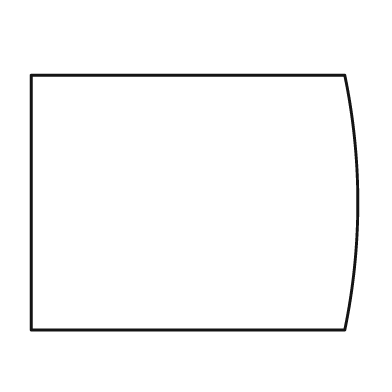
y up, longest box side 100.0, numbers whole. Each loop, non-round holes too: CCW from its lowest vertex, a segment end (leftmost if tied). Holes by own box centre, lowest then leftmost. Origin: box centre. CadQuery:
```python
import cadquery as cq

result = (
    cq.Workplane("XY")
    .moveTo(-50.0, -39.0)
    .lineTo(46.0, -39.0)
    .threePointArc((50.0, 0.0), (46.0, 39.0))
    .lineTo(-50.0, 39.0)
    .close()
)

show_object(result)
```